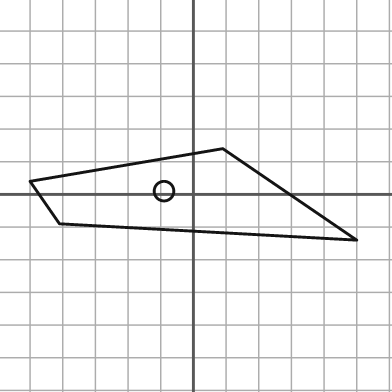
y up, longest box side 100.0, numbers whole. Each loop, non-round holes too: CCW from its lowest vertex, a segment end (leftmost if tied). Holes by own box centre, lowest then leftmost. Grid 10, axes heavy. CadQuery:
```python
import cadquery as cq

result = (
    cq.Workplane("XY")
    .moveTo(50.0, -14.0)
    .lineTo(9.0, 14.0)
    .lineTo(-50.0, 4.0)
    .lineTo(-41.0, -9.0)
    .close()
    .moveTo(-9.0, 1.0)
    .circle(3.0)
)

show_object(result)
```